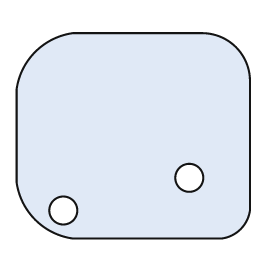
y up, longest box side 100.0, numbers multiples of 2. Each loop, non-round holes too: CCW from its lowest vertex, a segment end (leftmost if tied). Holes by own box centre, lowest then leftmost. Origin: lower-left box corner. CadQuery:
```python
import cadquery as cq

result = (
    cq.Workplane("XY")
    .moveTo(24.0, 0.0)
    .lineTo(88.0, 0.0)
    .threePointArc((96.0, 4.0), (100.0, 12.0))
    .lineTo(100.0, 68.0)
    .threePointArc((94.0, 82.0), (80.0, 88.0))
    .lineTo(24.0, 88.0)
    .threePointArc((8.0, 80.0), (0.0, 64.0))
    .lineTo(0.0, 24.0)
    .threePointArc((8.0, 8.0), (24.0, 0.0))
    .close()
    .moveTo(20.0, 12.0)
    .circle(6.0)
    .moveTo(74.0, 26.0)
    .circle(6.0)
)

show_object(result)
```